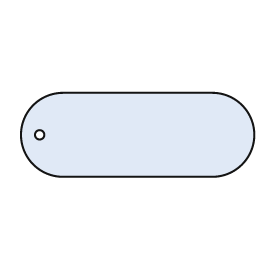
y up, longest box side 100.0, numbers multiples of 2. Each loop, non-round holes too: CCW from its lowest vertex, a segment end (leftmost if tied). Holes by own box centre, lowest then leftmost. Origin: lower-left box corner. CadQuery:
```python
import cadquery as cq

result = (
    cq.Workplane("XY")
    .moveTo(18.0, 0.0)
    .lineTo(82.0, 0.0)
    .threePointArc((100.0, 18.0), (82.0, 36.0))
    .lineTo(18.0, 36.0)
    .threePointArc((0.0, 18.0), (18.0, 0.0))
    .close()
    .moveTo(8.0, 18.0)
    .circle(2.0)
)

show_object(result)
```